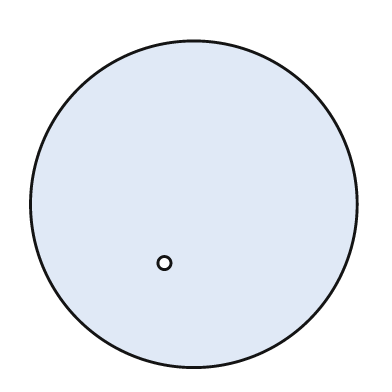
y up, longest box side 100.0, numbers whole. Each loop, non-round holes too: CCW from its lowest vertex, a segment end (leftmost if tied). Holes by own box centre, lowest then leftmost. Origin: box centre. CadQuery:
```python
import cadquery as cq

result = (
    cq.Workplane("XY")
    .moveTo(0.0, 0.0)
    .circle(50.0)
    .moveTo(-9.0, -18.0)
    .circle(2.0)
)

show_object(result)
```